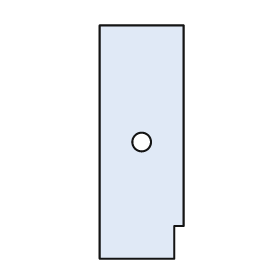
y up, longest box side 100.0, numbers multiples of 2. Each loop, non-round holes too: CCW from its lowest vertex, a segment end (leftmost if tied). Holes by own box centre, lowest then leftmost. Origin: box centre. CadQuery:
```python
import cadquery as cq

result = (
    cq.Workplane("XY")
    .moveTo(-18.0, -50.0)
    .lineTo(14.0, -50.0)
    .lineTo(14.0, -36.0)
    .lineTo(18.0, -36.0)
    .lineTo(18.0, 50.0)
    .lineTo(-18.0, 50.0)
    .close()
    .moveTo(0.0, 0.0)
    .circle(4.0)
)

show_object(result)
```